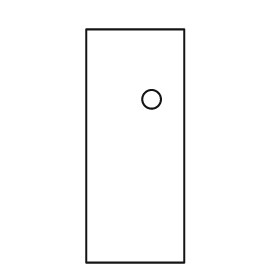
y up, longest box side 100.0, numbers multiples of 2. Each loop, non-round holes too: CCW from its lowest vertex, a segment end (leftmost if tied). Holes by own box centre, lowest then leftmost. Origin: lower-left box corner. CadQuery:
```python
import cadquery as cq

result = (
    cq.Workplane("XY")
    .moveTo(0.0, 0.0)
    .lineTo(42.0, 0.0)
    .lineTo(42.0, 100.0)
    .lineTo(0.0, 100.0)
    .close()
    .moveTo(28.0, 70.0)
    .circle(4.0)
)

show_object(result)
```